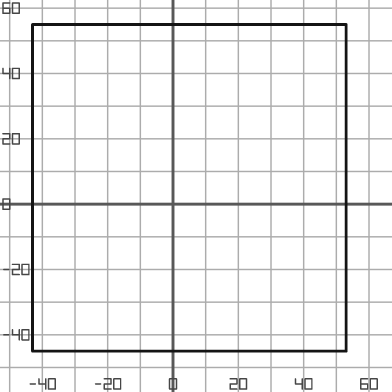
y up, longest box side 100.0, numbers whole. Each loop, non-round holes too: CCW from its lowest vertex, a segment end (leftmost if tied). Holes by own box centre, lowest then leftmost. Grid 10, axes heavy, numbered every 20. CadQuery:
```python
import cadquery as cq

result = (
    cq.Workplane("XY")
    .moveTo(-43.0, -45.0)
    .lineTo(53.0, -45.0)
    .lineTo(53.0, 55.0)
    .lineTo(-43.0, 55.0)
    .close()
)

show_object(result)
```